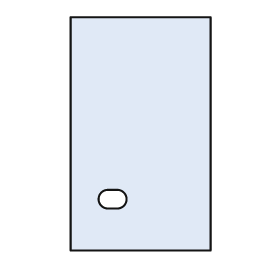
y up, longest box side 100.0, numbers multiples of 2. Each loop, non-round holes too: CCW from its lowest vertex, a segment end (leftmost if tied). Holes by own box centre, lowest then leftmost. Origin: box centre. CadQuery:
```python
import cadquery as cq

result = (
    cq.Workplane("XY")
    .moveTo(-30.0, -50.0)
    .lineTo(30.0, -50.0)
    .lineTo(30.0, 50.0)
    .lineTo(-30.0, 50.0)
    .close()
    .moveTo(-14.0, -32.0)
    .lineTo(-10.0, -32.0)
    .threePointArc((-6.0, -28.0), (-10.0, -24.0))
    .lineTo(-14.0, -24.0)
    .threePointArc((-18.0, -28.0), (-14.0, -32.0))
    .close()
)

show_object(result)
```